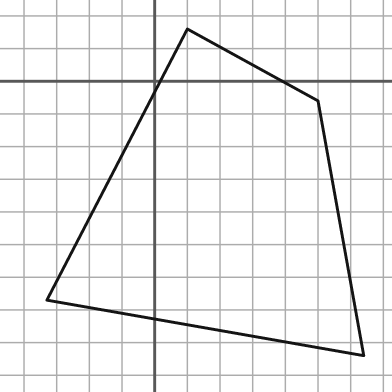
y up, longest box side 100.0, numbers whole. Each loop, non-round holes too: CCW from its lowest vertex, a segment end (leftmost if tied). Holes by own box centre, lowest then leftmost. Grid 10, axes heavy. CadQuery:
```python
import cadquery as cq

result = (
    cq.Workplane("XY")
    .moveTo(64.0, -84.0)
    .lineTo(50.0, -6.0)
    .lineTo(10.0, 16.0)
    .lineTo(-33.0, -67.0)
    .close()
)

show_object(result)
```